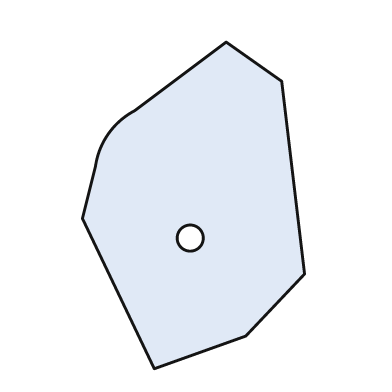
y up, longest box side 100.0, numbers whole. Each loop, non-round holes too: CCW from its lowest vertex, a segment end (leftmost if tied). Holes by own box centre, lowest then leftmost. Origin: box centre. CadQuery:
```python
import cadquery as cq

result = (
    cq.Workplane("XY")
    .moveTo(-12.0, -50.0)
    .lineTo(16.0, -40.0)
    .lineTo(34.0, -21.0)
    .lineTo(27.0, 38.0)
    .lineTo(10.0, 50.0)
    .lineTo(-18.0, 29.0)
    .threePointArc((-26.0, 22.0), (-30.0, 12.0))
    .lineTo(-34.0, -4.0)
    .close()
    .moveTo(-1.0, -10.0)
    .circle(4.0)
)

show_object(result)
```